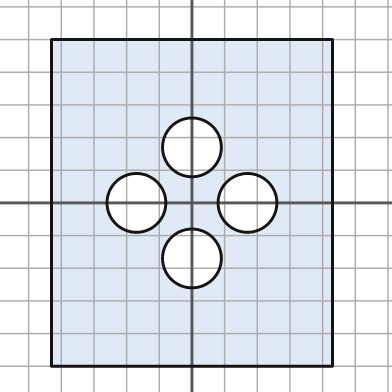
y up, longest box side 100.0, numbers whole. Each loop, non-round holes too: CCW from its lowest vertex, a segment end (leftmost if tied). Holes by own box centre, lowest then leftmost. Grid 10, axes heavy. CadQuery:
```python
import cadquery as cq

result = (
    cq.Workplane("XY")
    .moveTo(-43.0, -50.0)
    .lineTo(43.0, -50.0)
    .lineTo(43.0, 50.0)
    .lineTo(-43.0, 50.0)
    .close()
    .moveTo(0.0, -17.0)
    .circle(9.0)
    .moveTo(-17.0, 0.0)
    .circle(9.0)
    .moveTo(17.0, 0.0)
    .circle(9.0)
    .moveTo(0.0, 17.0)
    .circle(9.0)
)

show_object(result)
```